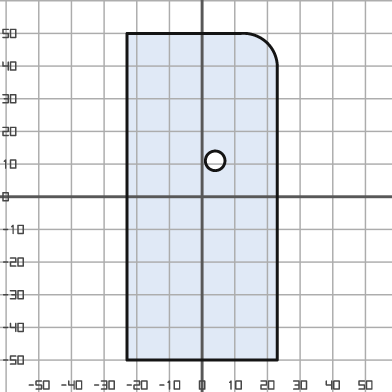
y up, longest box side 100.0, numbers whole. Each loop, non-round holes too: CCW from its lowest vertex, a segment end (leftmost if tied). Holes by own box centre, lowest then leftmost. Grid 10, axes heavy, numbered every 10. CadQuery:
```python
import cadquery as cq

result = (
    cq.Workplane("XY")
    .moveTo(-23.0, -50.0)
    .lineTo(23.0, -50.0)
    .lineTo(23.0, 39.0)
    .threePointArc((20.0, 47.0), (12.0, 50.0))
    .lineTo(-23.0, 50.0)
    .close()
    .moveTo(4.0, 11.0)
    .circle(3.0)
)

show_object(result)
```